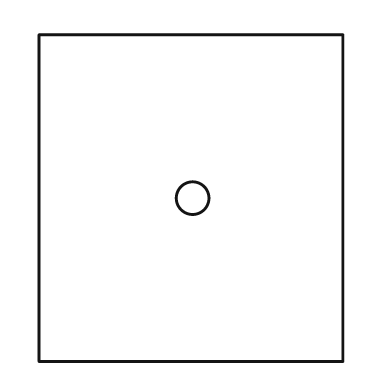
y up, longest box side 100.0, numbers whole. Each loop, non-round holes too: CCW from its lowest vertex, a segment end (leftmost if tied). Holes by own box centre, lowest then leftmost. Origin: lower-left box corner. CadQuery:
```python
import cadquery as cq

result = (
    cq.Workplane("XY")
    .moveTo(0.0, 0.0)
    .lineTo(93.0, 0.0)
    .lineTo(93.0, 100.0)
    .lineTo(0.0, 100.0)
    .close()
    .moveTo(47.0, 50.0)
    .circle(5.0)
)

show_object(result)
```